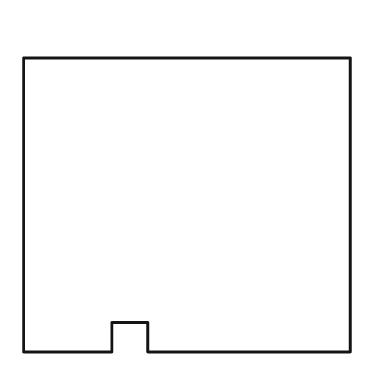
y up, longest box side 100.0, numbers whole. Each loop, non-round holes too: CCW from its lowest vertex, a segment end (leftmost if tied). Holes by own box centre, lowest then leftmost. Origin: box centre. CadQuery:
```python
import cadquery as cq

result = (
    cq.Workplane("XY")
    .moveTo(-50.0, -45.0)
    .lineTo(-23.0, -45.0)
    .lineTo(-23.0, -36.0)
    .lineTo(-12.0, -36.0)
    .lineTo(-12.0, -45.0)
    .lineTo(50.0, -45.0)
    .lineTo(50.0, 45.0)
    .lineTo(-50.0, 45.0)
    .close()
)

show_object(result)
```